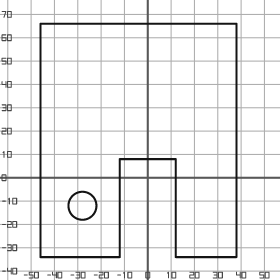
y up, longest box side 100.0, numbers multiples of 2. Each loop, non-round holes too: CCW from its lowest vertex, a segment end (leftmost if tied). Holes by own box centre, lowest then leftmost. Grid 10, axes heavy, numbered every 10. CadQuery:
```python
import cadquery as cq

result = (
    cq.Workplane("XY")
    .moveTo(-46.0, -34.0)
    .lineTo(-12.0, -34.0)
    .lineTo(-12.0, 8.0)
    .lineTo(12.0, 8.0)
    .lineTo(12.0, -34.0)
    .lineTo(38.0, -34.0)
    .lineTo(38.0, 66.0)
    .lineTo(-46.0, 66.0)
    .close()
    .moveTo(-28.0, -12.0)
    .circle(6.0)
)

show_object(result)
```